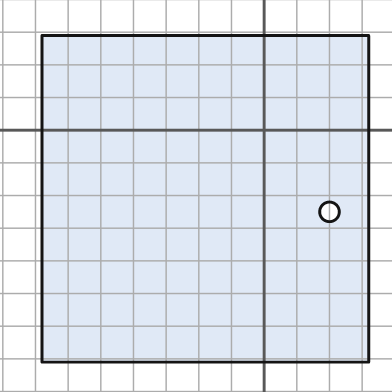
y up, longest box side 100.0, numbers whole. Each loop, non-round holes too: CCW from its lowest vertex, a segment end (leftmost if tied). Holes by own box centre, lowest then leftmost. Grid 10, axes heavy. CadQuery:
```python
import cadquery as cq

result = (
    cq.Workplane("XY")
    .moveTo(-68.0, -71.0)
    .lineTo(32.0, -71.0)
    .lineTo(32.0, 29.0)
    .lineTo(-68.0, 29.0)
    .close()
    .moveTo(20.0, -25.0)
    .circle(3.0)
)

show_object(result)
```